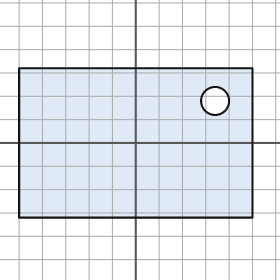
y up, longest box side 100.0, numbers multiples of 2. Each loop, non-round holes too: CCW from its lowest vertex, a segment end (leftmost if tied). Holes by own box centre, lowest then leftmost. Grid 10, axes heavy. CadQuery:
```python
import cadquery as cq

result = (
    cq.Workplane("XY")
    .moveTo(-50.0, -32.0)
    .lineTo(50.0, -32.0)
    .lineTo(50.0, 32.0)
    .lineTo(-50.0, 32.0)
    .close()
    .moveTo(34.0, 18.0)
    .circle(6.0)
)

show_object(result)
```